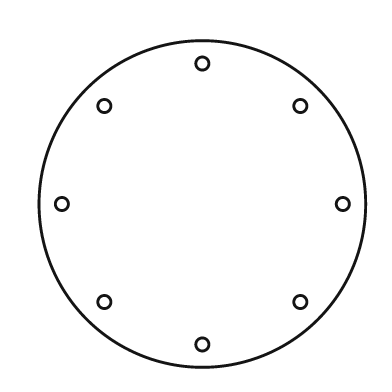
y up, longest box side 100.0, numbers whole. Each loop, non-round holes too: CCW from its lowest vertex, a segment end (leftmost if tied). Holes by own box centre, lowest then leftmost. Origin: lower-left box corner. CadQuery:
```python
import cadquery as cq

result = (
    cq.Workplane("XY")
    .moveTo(50.0, 50.0)
    .circle(50.0)
    .moveTo(50.0, 7.0)
    .circle(2.0)
    .moveTo(20.0, 20.0)
    .circle(2.0)
    .moveTo(80.0, 20.0)
    .circle(2.0)
    .moveTo(7.0, 50.0)
    .circle(2.0)
    .moveTo(93.0, 50.0)
    .circle(2.0)
    .moveTo(20.0, 80.0)
    .circle(2.0)
    .moveTo(80.0, 80.0)
    .circle(2.0)
    .moveTo(50.0, 93.0)
    .circle(2.0)
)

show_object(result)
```